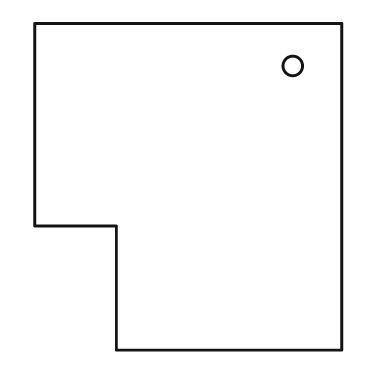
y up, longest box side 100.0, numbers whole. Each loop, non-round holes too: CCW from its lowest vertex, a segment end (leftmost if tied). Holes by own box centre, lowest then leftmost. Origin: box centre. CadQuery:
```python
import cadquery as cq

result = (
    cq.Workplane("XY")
    .moveTo(-22.0, -50.0)
    .lineTo(47.0, -50.0)
    .lineTo(47.0, 50.0)
    .lineTo(-47.0, 50.0)
    .lineTo(-47.0, -12.0)
    .lineTo(-22.0, -12.0)
    .close()
    .moveTo(32.0, 37.0)
    .circle(3.0)
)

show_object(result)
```